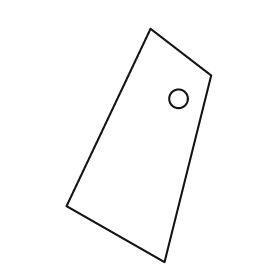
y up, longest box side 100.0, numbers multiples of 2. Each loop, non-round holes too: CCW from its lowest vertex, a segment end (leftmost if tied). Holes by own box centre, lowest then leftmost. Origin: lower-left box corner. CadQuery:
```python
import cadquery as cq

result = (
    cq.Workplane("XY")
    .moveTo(42.0, 0.0)
    .lineTo(62.0, 80.0)
    .lineTo(36.0, 100.0)
    .lineTo(0.0, 24.0)
    .close()
    .moveTo(48.0, 70.0)
    .circle(4.0)
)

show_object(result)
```